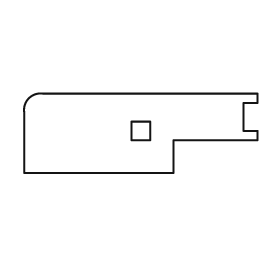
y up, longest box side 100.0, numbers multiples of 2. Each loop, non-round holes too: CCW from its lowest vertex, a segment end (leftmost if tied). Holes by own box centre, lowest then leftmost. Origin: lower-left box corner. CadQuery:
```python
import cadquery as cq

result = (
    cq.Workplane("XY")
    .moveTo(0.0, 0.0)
    .lineTo(64.0, 0.0)
    .lineTo(64.0, 14.0)
    .lineTo(100.0, 14.0)
    .lineTo(100.0, 18.0)
    .lineTo(94.0, 18.0)
    .lineTo(94.0, 30.0)
    .lineTo(100.0, 30.0)
    .lineTo(100.0, 34.0)
    .lineTo(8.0, 34.0)
    .threePointArc((2.0, 32.0), (0.0, 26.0))
    .close()
    .moveTo(46.0, 14.0)
    .lineTo(54.0, 14.0)
    .lineTo(54.0, 22.0)
    .lineTo(46.0, 22.0)
    .close()
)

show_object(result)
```